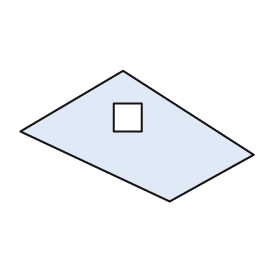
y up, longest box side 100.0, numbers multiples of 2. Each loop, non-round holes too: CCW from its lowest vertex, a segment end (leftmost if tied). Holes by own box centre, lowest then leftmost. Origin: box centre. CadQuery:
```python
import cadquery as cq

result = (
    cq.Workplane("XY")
    .moveTo(14.0, -28.0)
    .lineTo(50.0, -8.0)
    .lineTo(-6.0, 28.0)
    .lineTo(-50.0, 2.0)
    .close()
    .moveTo(-10.0, 2.0)
    .lineTo(2.0, 2.0)
    .lineTo(2.0, 14.0)
    .lineTo(-10.0, 14.0)
    .close()
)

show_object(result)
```